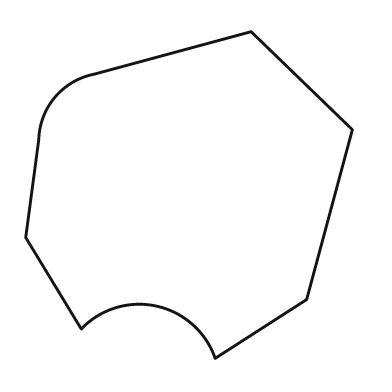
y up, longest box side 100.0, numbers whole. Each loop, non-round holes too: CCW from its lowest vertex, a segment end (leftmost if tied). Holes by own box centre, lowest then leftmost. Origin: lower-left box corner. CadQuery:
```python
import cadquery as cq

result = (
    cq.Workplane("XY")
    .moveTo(58.0, 0.0)
    .lineTo(86.0, 18.0)
    .lineTo(100.0, 70.0)
    .lineTo(69.0, 100.0)
    .lineTo(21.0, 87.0)
    .threePointArc((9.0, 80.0), (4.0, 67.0))
    .lineTo(0.0, 37.0)
    .lineTo(17.0, 9.0)
    .threePointArc((40.0, 16.0), (58.0, 0.0))
    .close()
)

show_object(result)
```